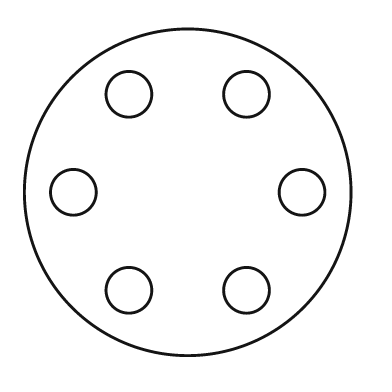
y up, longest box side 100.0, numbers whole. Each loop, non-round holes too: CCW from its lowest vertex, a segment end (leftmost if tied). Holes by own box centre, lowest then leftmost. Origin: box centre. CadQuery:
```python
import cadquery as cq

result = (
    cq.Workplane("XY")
    .moveTo(0.0, 0.0)
    .circle(50.0)
    .moveTo(-18.0, -30.0)
    .circle(7.0)
    .moveTo(18.0, -30.0)
    .circle(7.0)
    .moveTo(-35.0, 0.0)
    .circle(7.0)
    .moveTo(35.0, 0.0)
    .circle(7.0)
    .moveTo(-18.0, 30.0)
    .circle(7.0)
    .moveTo(18.0, 30.0)
    .circle(7.0)
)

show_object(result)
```